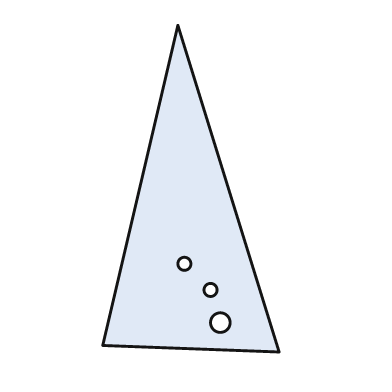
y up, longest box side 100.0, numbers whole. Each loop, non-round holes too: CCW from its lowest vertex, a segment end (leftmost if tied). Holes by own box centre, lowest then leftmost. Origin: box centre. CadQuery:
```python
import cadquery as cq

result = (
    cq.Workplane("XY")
    .moveTo(27.0, -50.0)
    .lineTo(-4.0, 50.0)
    .lineTo(-27.0, -48.0)
    .close()
    .moveTo(9.0, -41.0)
    .circle(3.0)
    .moveTo(6.0, -31.0)
    .circle(2.0)
    .moveTo(-2.0, -23.0)
    .circle(2.0)
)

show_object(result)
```